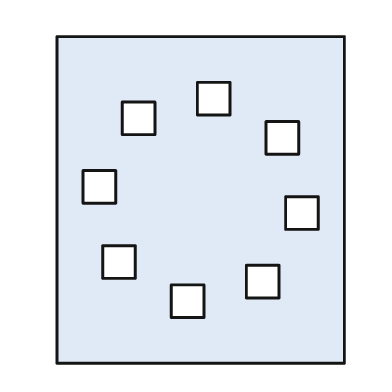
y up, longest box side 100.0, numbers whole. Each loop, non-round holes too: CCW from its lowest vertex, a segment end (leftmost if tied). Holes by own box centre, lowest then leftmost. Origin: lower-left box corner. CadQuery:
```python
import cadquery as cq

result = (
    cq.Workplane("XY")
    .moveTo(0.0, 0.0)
    .lineTo(88.0, 0.0)
    .lineTo(88.0, 100.0)
    .lineTo(0.0, 100.0)
    .close()
    .moveTo(35.0, 14.0)
    .lineTo(45.0, 14.0)
    .lineTo(45.0, 24.0)
    .lineTo(35.0, 24.0)
    .close()
    .moveTo(58.0, 20.0)
    .lineTo(68.0, 20.0)
    .lineTo(68.0, 30.0)
    .lineTo(58.0, 30.0)
    .close()
    .moveTo(14.0, 26.0)
    .lineTo(24.0, 26.0)
    .lineTo(24.0, 36.0)
    .lineTo(14.0, 36.0)
    .close()
    .moveTo(70.0, 41.0)
    .lineTo(80.0, 41.0)
    .lineTo(80.0, 51.0)
    .lineTo(70.0, 51.0)
    .close()
    .moveTo(8.0, 49.0)
    .lineTo(18.0, 49.0)
    .lineTo(18.0, 59.0)
    .lineTo(8.0, 59.0)
    .close()
    .moveTo(64.0, 64.0)
    .lineTo(74.0, 64.0)
    .lineTo(74.0, 74.0)
    .lineTo(64.0, 74.0)
    .close()
    .moveTo(20.0, 70.0)
    .lineTo(30.0, 70.0)
    .lineTo(30.0, 80.0)
    .lineTo(20.0, 80.0)
    .close()
    .moveTo(43.0, 76.0)
    .lineTo(53.0, 76.0)
    .lineTo(53.0, 86.0)
    .lineTo(43.0, 86.0)
    .close()
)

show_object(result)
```